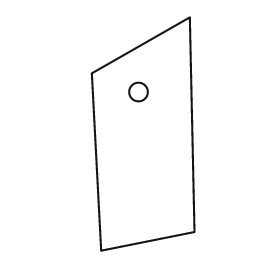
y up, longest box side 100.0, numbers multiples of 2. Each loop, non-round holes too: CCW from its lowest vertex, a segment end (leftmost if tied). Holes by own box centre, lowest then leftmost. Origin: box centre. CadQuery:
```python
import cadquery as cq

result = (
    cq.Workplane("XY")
    .moveTo(-18.0, -50.0)
    .lineTo(22.0, -42.0)
    .lineTo(20.0, 50.0)
    .lineTo(-22.0, 26.0)
    .close()
    .moveTo(-2.0, 18.0)
    .circle(4.0)
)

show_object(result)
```